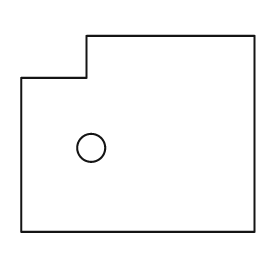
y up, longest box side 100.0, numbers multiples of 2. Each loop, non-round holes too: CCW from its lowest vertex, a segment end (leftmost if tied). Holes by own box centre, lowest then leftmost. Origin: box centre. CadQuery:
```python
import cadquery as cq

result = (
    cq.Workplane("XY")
    .moveTo(-50.0, -42.0)
    .lineTo(50.0, -42.0)
    .lineTo(50.0, 42.0)
    .lineTo(-22.0, 42.0)
    .lineTo(-22.0, 24.0)
    .lineTo(-50.0, 24.0)
    .close()
    .moveTo(-20.0, -6.0)
    .circle(6.0)
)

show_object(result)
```